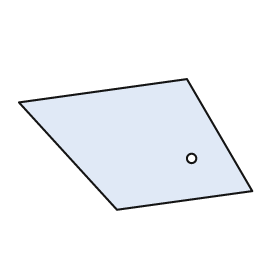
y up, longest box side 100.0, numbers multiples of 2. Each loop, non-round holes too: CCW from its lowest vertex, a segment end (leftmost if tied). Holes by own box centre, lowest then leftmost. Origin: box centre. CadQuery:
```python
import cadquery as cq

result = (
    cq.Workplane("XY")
    .moveTo(-8.0, -28.0)
    .lineTo(50.0, -20.0)
    .lineTo(22.0, 28.0)
    .lineTo(-50.0, 18.0)
    .close()
    .moveTo(24.0, -6.0)
    .circle(2.0)
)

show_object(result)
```